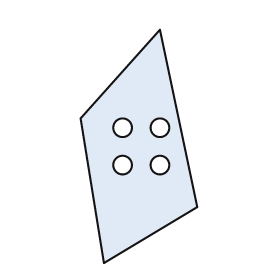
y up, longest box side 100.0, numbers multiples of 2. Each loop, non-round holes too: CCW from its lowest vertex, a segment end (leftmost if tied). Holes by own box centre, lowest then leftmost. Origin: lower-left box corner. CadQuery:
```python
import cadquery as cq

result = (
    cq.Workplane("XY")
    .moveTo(10.0, 0.0)
    .lineTo(50.0, 24.0)
    .lineTo(34.0, 100.0)
    .lineTo(0.0, 62.0)
    .close()
    .moveTo(18.0, 42.0)
    .circle(4.0)
    .moveTo(34.0, 42.0)
    .circle(4.0)
    .moveTo(18.0, 58.0)
    .circle(4.0)
    .moveTo(34.0, 58.0)
    .circle(4.0)
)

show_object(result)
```